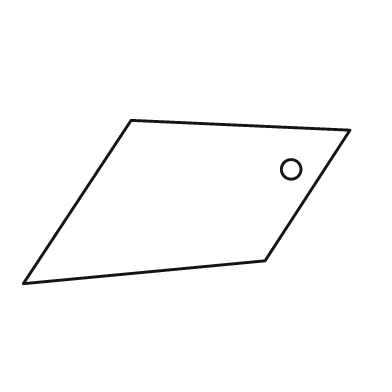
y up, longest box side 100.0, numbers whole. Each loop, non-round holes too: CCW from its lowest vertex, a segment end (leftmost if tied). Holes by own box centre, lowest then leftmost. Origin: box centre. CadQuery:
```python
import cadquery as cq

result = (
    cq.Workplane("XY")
    .moveTo(-50.0, -25.0)
    .lineTo(24.0, -18.0)
    .lineTo(50.0, 22.0)
    .lineTo(-17.0, 25.0)
    .close()
    .moveTo(32.0, 10.0)
    .circle(3.0)
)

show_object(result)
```